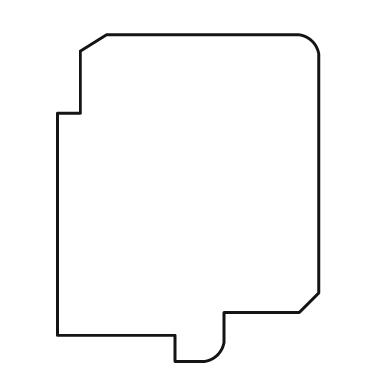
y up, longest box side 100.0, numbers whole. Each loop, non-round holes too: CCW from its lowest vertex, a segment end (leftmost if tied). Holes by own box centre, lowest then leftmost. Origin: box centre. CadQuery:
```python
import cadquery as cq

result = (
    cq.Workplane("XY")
    .moveTo(-4.0, -50.0)
    .lineTo(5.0, -50.0)
    .threePointArc((9.0, -48.0), (11.0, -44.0))
    .lineTo(11.0, -35.0)
    .lineTo(34.0, -35.0)
    .lineTo(40.0, -29.0)
    .lineTo(40.0, 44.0)
    .threePointArc((38.0, 48.0), (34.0, 50.0))
    .lineTo(-25.0, 50.0)
    .lineTo(-33.0, 45.0)
    .lineTo(-33.0, 26.0)
    .lineTo(-40.0, 26.0)
    .lineTo(-40.0, -42.0)
    .lineTo(-4.0, -42.0)
    .close()
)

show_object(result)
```